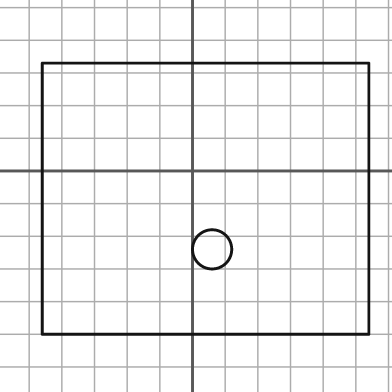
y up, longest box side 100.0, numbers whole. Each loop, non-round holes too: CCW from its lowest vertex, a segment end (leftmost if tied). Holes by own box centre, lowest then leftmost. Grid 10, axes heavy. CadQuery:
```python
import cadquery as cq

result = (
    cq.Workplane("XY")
    .moveTo(-46.0, -50.0)
    .lineTo(54.0, -50.0)
    .lineTo(54.0, 33.0)
    .lineTo(-46.0, 33.0)
    .close()
    .moveTo(6.0, -24.0)
    .circle(6.0)
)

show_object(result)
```